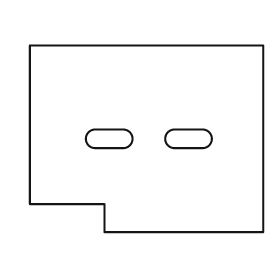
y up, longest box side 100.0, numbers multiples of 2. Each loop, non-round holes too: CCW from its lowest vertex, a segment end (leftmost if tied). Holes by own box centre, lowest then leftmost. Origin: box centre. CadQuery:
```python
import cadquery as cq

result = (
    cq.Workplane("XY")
    .moveTo(-18.0, -40.0)
    .lineTo(50.0, -40.0)
    .lineTo(50.0, 40.0)
    .lineTo(-50.0, 40.0)
    .lineTo(-50.0, -28.0)
    .lineTo(-18.0, -28.0)
    .close()
    .moveTo(-22.0, -4.0)
    .lineTo(-10.0, -4.0)
    .threePointArc((-6.0, 0.0), (-10.0, 4.0))
    .lineTo(-22.0, 4.0)
    .threePointArc((-26.0, 0.0), (-22.0, -4.0))
    .close()
    .moveTo(12.0, -4.0)
    .lineTo(24.0, -4.0)
    .threePointArc((28.0, 0.0), (24.0, 4.0))
    .lineTo(12.0, 4.0)
    .threePointArc((8.0, 0.0), (12.0, -4.0))
    .close()
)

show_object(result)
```